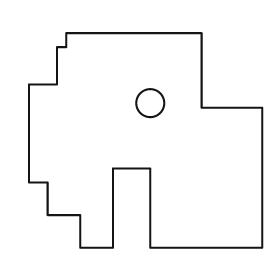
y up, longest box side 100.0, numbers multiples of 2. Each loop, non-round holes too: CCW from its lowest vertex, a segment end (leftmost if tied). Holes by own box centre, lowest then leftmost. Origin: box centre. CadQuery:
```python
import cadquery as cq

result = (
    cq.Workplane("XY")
    .moveTo(-28.0, -46.0)
    .lineTo(-14.0, -46.0)
    .lineTo(-14.0, -12.0)
    .lineTo(2.0, -12.0)
    .lineTo(2.0, -46.0)
    .lineTo(50.0, -46.0)
    .lineTo(50.0, 14.0)
    .lineTo(24.0, 14.0)
    .lineTo(24.0, 46.0)
    .lineTo(-34.0, 46.0)
    .lineTo(-34.0, 40.0)
    .lineTo(-38.0, 40.0)
    .lineTo(-38.0, 24.0)
    .lineTo(-50.0, 24.0)
    .lineTo(-50.0, -18.0)
    .lineTo(-42.0, -18.0)
    .lineTo(-42.0, -32.0)
    .lineTo(-28.0, -32.0)
    .close()
    .moveTo(2.0, 16.0)
    .circle(6.0)
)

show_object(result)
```